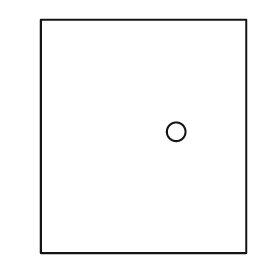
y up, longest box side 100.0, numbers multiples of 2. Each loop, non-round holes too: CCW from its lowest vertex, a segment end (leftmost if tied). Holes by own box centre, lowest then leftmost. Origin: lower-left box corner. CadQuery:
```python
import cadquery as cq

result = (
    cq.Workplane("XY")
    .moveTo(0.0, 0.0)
    .lineTo(88.0, 0.0)
    .lineTo(88.0, 100.0)
    .lineTo(0.0, 100.0)
    .close()
    .moveTo(58.0, 52.0)
    .circle(4.0)
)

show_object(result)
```